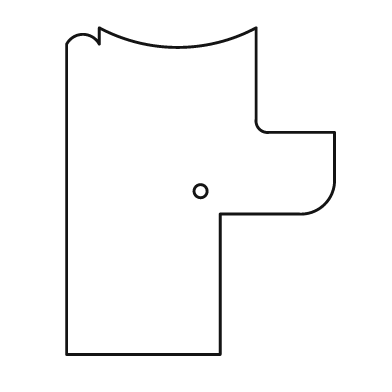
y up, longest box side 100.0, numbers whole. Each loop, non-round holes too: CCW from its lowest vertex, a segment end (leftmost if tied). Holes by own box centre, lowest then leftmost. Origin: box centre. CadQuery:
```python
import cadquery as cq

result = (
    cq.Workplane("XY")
    .moveTo(-41.0, -50.0)
    .lineTo(6.0, -50.0)
    .lineTo(6.0, -7.0)
    .lineTo(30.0, -7.0)
    .threePointArc((38.0, -4.0), (41.0, 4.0))
    .lineTo(41.0, 18.0)
    .lineTo(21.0, 18.0)
    .threePointArc((18.0, 19.0), (17.0, 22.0))
    .lineTo(17.0, 50.0)
    .threePointArc((-7.0, 44.0), (-31.0, 50.0))
    .lineTo(-31.0, 45.0)
    .threePointArc((-36.0, 48.0), (-41.0, 45.0))
    .close()
    .moveTo(0.0, 0.0)
    .circle(2.0)
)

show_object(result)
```